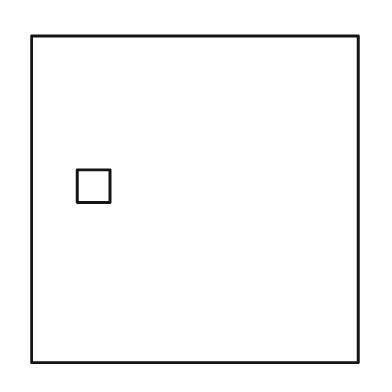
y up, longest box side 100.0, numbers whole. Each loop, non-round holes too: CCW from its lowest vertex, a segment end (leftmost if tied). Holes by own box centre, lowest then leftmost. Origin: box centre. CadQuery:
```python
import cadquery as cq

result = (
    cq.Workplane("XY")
    .moveTo(-50.0, -50.0)
    .lineTo(50.0, -50.0)
    .lineTo(50.0, 50.0)
    .lineTo(-50.0, 50.0)
    .close()
    .moveTo(-36.0, -1.0)
    .lineTo(-26.0, -1.0)
    .lineTo(-26.0, 9.0)
    .lineTo(-36.0, 9.0)
    .close()
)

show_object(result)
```